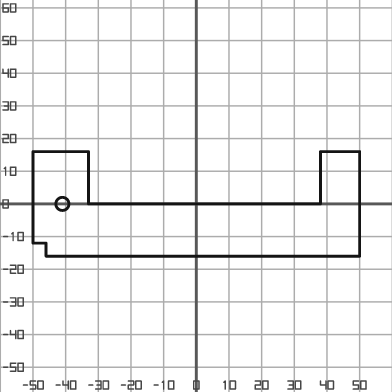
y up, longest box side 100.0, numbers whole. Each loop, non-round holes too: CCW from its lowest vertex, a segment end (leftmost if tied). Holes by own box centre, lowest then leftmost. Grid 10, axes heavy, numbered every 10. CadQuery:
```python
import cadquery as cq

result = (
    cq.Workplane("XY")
    .moveTo(-46.0, -16.0)
    .lineTo(50.0, -16.0)
    .lineTo(50.0, 16.0)
    .lineTo(38.0, 16.0)
    .lineTo(38.0, 0.0)
    .lineTo(-33.0, 0.0)
    .lineTo(-33.0, 16.0)
    .lineTo(-50.0, 16.0)
    .lineTo(-50.0, -12.0)
    .lineTo(-46.0, -12.0)
    .close()
    .moveTo(-41.0, 0.0)
    .circle(2.0)
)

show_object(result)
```